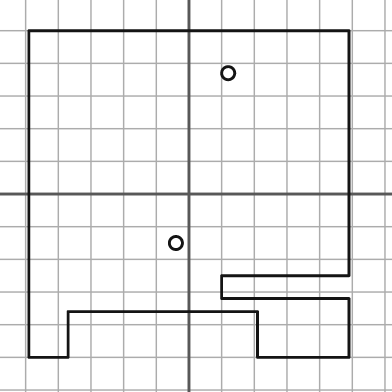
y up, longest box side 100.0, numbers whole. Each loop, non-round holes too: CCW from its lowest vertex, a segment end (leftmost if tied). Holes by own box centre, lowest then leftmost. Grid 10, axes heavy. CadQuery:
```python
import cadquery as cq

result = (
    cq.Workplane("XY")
    .moveTo(-49.0, -50.0)
    .lineTo(-37.0, -50.0)
    .lineTo(-37.0, -36.0)
    .lineTo(21.0, -36.0)
    .lineTo(21.0, -50.0)
    .lineTo(49.0, -50.0)
    .lineTo(49.0, -32.0)
    .lineTo(10.0, -32.0)
    .lineTo(10.0, -25.0)
    .lineTo(49.0, -25.0)
    .lineTo(49.0, 50.0)
    .lineTo(-49.0, 50.0)
    .close()
    .moveTo(-4.0, -15.0)
    .circle(2.0)
    .moveTo(12.0, 37.0)
    .circle(2.0)
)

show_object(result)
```